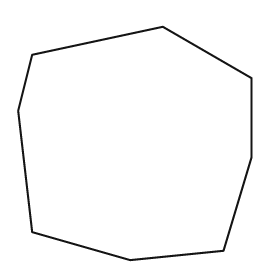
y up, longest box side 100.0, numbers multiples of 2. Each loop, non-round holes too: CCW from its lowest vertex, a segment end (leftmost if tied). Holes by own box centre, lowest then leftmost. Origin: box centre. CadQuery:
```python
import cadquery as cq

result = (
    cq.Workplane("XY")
    .moveTo(-2.0, -50.0)
    .lineTo(38.0, -46.0)
    .lineTo(50.0, -6.0)
    .lineTo(50.0, 28.0)
    .lineTo(12.0, 50.0)
    .lineTo(-44.0, 38.0)
    .lineTo(-50.0, 14.0)
    .lineTo(-44.0, -38.0)
    .close()
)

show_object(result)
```